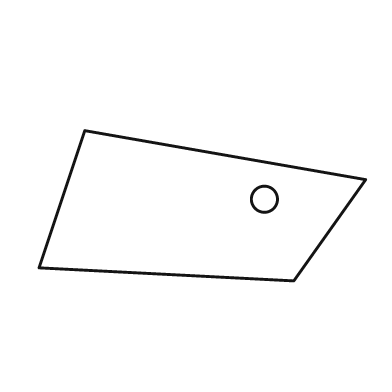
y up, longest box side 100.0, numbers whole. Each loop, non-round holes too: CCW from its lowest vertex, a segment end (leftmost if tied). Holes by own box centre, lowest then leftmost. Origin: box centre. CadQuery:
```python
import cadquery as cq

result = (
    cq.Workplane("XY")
    .moveTo(28.0, -23.0)
    .lineTo(50.0, 8.0)
    .lineTo(-36.0, 23.0)
    .lineTo(-50.0, -19.0)
    .close()
    .moveTo(19.0, 2.0)
    .circle(4.0)
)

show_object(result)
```